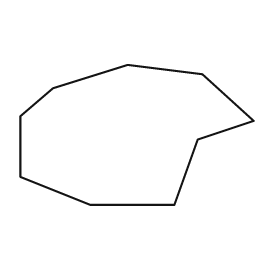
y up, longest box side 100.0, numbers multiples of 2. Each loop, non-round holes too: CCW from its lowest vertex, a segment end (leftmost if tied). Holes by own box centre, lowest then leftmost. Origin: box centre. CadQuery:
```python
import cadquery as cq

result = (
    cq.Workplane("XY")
    .moveTo(-20.0, -30.0)
    .lineTo(16.0, -30.0)
    .lineTo(26.0, -2.0)
    .lineTo(50.0, 6.0)
    .lineTo(28.0, 26.0)
    .lineTo(-4.0, 30.0)
    .lineTo(-36.0, 20.0)
    .lineTo(-50.0, 8.0)
    .lineTo(-50.0, -18.0)
    .close()
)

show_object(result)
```